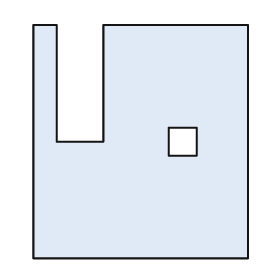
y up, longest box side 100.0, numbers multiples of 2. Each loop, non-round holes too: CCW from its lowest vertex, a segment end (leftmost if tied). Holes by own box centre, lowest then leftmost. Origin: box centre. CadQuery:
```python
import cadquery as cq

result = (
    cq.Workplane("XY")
    .moveTo(-46.0, -50.0)
    .lineTo(46.0, -50.0)
    .lineTo(46.0, 50.0)
    .lineTo(-16.0, 50.0)
    .lineTo(-16.0, 0.0)
    .lineTo(-36.0, 0.0)
    .lineTo(-36.0, 50.0)
    .lineTo(-46.0, 50.0)
    .close()
    .moveTo(12.0, -6.0)
    .lineTo(24.0, -6.0)
    .lineTo(24.0, 6.0)
    .lineTo(12.0, 6.0)
    .close()
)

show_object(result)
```